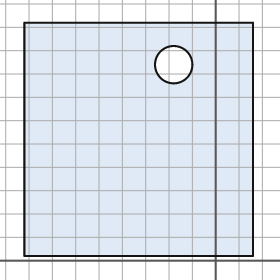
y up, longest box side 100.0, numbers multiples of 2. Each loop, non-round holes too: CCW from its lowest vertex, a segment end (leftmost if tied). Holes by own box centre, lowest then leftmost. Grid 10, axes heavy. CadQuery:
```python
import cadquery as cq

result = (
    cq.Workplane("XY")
    .moveTo(-82.0, 2.0)
    .lineTo(16.0, 2.0)
    .lineTo(16.0, 102.0)
    .lineTo(-82.0, 102.0)
    .close()
    .moveTo(-18.0, 84.0)
    .circle(8.0)
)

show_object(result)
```